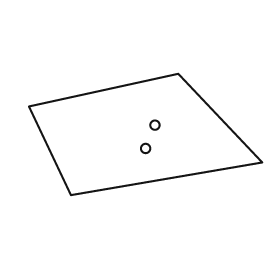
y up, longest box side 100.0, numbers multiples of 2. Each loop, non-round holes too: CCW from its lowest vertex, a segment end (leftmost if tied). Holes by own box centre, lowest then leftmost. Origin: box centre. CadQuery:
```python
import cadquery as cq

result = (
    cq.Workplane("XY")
    .moveTo(-32.0, -26.0)
    .lineTo(50.0, -12.0)
    .lineTo(14.0, 26.0)
    .lineTo(-50.0, 12.0)
    .close()
    .moveTo(0.0, -6.0)
    .circle(2.0)
    .moveTo(4.0, 4.0)
    .circle(2.0)
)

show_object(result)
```